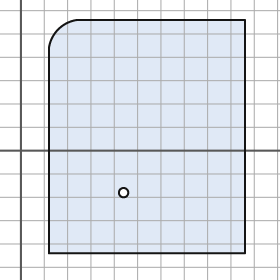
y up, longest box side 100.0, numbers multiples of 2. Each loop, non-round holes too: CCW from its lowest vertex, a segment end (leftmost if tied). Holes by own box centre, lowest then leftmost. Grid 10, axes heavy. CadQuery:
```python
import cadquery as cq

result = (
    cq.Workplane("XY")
    .moveTo(12.0, -44.0)
    .lineTo(96.0, -44.0)
    .lineTo(96.0, 56.0)
    .lineTo(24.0, 56.0)
    .threePointArc((16.0, 52.0), (12.0, 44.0))
    .close()
    .moveTo(44.0, -18.0)
    .circle(2.0)
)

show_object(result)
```